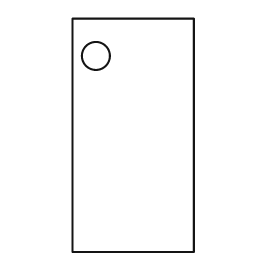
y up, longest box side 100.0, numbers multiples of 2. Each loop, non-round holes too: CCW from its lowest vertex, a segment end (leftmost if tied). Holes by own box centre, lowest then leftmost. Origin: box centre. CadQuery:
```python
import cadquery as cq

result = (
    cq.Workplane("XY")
    .moveTo(-26.0, -50.0)
    .lineTo(26.0, -50.0)
    .lineTo(26.0, 50.0)
    .lineTo(-26.0, 50.0)
    .close()
    .moveTo(-16.0, 34.0)
    .circle(6.0)
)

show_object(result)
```